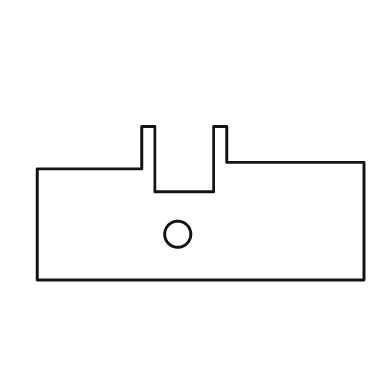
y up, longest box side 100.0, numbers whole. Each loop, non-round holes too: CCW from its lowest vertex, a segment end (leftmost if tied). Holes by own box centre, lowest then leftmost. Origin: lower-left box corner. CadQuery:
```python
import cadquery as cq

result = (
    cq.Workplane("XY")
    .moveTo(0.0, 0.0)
    .lineTo(100.0, 0.0)
    .lineTo(100.0, 36.0)
    .lineTo(58.0, 36.0)
    .lineTo(58.0, 47.0)
    .lineTo(54.0, 47.0)
    .lineTo(54.0, 27.0)
    .lineTo(36.0, 27.0)
    .lineTo(36.0, 47.0)
    .lineTo(32.0, 47.0)
    .lineTo(32.0, 34.0)
    .lineTo(0.0, 34.0)
    .close()
    .moveTo(43.0, 14.0)
    .circle(4.0)
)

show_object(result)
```